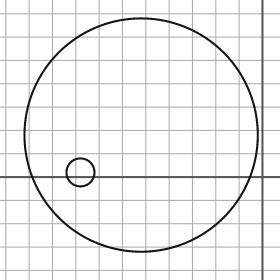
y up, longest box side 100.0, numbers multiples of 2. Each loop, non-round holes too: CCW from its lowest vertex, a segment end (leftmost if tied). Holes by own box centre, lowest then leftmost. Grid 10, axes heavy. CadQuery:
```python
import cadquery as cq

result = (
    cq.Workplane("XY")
    .moveTo(-52.0, 18.0)
    .circle(50.0)
    .moveTo(-78.0, 2.0)
    .circle(6.0)
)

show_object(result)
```